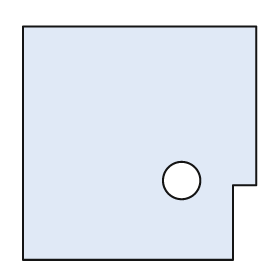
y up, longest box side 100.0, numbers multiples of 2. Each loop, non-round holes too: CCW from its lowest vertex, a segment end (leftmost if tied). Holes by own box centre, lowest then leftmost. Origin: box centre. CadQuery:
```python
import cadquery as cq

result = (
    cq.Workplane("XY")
    .moveTo(-50.0, -50.0)
    .lineTo(40.0, -50.0)
    .lineTo(40.0, -18.0)
    .lineTo(50.0, -18.0)
    .lineTo(50.0, 50.0)
    .lineTo(-50.0, 50.0)
    .close()
    .moveTo(18.0, -16.0)
    .circle(8.0)
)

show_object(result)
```